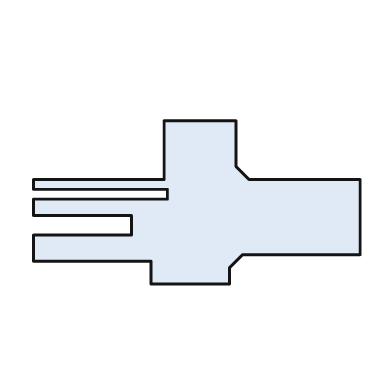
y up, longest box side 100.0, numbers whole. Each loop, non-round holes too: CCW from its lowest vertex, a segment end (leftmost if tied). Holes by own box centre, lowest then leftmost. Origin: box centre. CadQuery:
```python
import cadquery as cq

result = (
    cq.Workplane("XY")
    .moveTo(-14.0, -25.0)
    .lineTo(10.0, -25.0)
    .lineTo(10.0, -20.0)
    .lineTo(14.0, -16.0)
    .lineTo(50.0, -16.0)
    .lineTo(50.0, 7.0)
    .lineTo(16.0, 7.0)
    .lineTo(12.0, 11.0)
    .lineTo(12.0, 25.0)
    .lineTo(-10.0, 25.0)
    .lineTo(-10.0, 7.0)
    .lineTo(-50.0, 7.0)
    .lineTo(-50.0, 4.0)
    .lineTo(-9.0, 4.0)
    .lineTo(-9.0, 1.0)
    .lineTo(-50.0, 1.0)
    .lineTo(-50.0, -4.0)
    .lineTo(-20.0, -4.0)
    .lineTo(-20.0, -10.0)
    .lineTo(-50.0, -10.0)
    .lineTo(-50.0, -18.0)
    .lineTo(-14.0, -18.0)
    .close()
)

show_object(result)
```